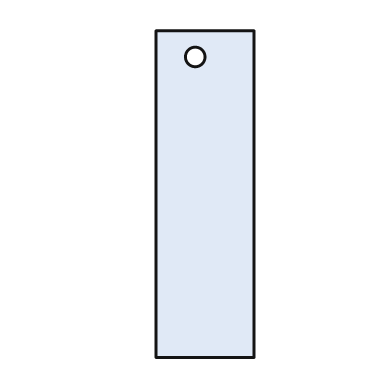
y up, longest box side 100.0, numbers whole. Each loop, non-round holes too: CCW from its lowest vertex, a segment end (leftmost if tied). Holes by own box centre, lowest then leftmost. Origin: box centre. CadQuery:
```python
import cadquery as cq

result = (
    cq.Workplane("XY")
    .moveTo(-15.0, -50.0)
    .lineTo(15.0, -50.0)
    .lineTo(15.0, 50.0)
    .lineTo(-15.0, 50.0)
    .close()
    .moveTo(-3.0, 42.0)
    .circle(3.0)
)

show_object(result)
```